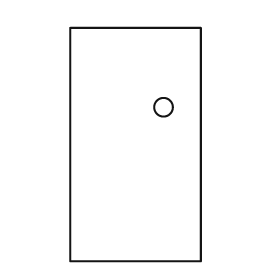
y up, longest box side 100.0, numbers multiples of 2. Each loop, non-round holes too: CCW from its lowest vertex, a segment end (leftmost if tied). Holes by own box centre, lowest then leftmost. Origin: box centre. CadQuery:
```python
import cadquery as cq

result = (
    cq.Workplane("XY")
    .moveTo(-28.0, -50.0)
    .lineTo(28.0, -50.0)
    .lineTo(28.0, 50.0)
    .lineTo(-28.0, 50.0)
    .close()
    .moveTo(12.0, 16.0)
    .circle(4.0)
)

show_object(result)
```